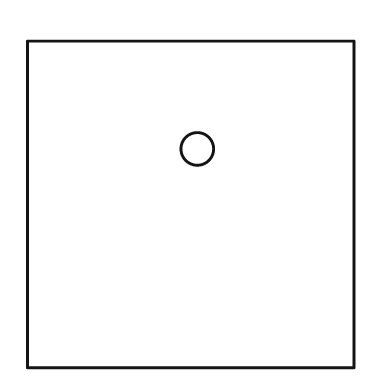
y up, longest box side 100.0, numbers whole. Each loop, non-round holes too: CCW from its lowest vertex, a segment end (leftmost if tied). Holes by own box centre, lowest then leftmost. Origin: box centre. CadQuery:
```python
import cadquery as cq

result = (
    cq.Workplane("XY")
    .moveTo(-50.0, -50.0)
    .lineTo(50.0, -50.0)
    .lineTo(50.0, 50.0)
    .lineTo(-50.0, 50.0)
    .close()
    .moveTo(2.0, 17.0)
    .circle(5.0)
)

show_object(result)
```